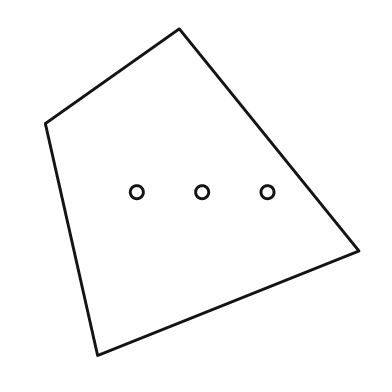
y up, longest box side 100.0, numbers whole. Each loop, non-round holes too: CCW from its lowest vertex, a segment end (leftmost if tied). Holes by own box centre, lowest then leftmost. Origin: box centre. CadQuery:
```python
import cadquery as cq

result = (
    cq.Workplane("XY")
    .moveTo(-32.0, -50.0)
    .lineTo(48.0, -18.0)
    .lineTo(-7.0, 50.0)
    .lineTo(-48.0, 21.0)
    .close()
    .moveTo(-20.0, 0.0)
    .circle(2.0)
    .moveTo(0.0, 0.0)
    .circle(2.0)
    .moveTo(20.0, 0.0)
    .circle(2.0)
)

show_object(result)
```